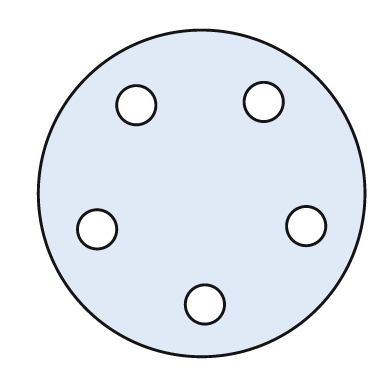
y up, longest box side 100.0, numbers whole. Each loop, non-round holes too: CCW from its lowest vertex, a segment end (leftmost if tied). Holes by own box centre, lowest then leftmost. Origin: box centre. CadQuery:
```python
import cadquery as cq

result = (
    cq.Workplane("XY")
    .moveTo(0.0, 0.0)
    .circle(50.0)
    .moveTo(1.0, -34.0)
    .circle(6.0)
    .moveTo(-32.0, -11.0)
    .circle(6.0)
    .moveTo(32.0, -10.0)
    .circle(6.0)
    .moveTo(-20.0, 27.0)
    .circle(6.0)
    .moveTo(19.0, 28.0)
    .circle(6.0)
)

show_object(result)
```